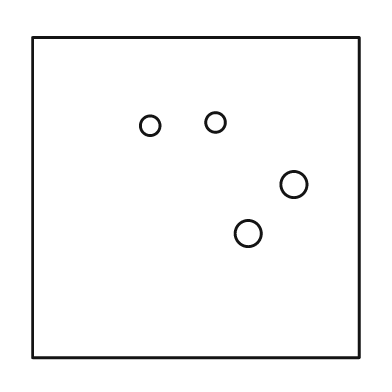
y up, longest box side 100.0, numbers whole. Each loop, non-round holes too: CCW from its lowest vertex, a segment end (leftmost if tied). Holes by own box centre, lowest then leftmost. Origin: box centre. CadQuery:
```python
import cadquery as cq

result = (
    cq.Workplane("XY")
    .moveTo(-50.0, -49.0)
    .lineTo(50.0, -49.0)
    .lineTo(50.0, 49.0)
    .lineTo(-50.0, 49.0)
    .close()
    .moveTo(16.0, -11.0)
    .circle(4.0)
    .moveTo(30.0, 4.0)
    .circle(4.0)
    .moveTo(-14.0, 22.0)
    .circle(3.0)
    .moveTo(6.0, 23.0)
    .circle(3.0)
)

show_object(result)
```